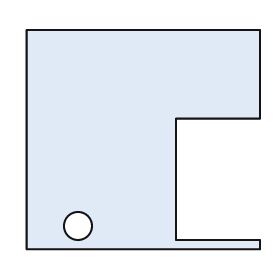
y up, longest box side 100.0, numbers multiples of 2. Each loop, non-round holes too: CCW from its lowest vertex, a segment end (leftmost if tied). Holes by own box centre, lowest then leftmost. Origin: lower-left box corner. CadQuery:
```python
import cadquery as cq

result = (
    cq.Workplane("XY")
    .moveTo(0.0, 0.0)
    .lineTo(100.0, 0.0)
    .lineTo(100.0, 4.0)
    .lineTo(64.0, 4.0)
    .lineTo(64.0, 56.0)
    .lineTo(100.0, 56.0)
    .lineTo(100.0, 94.0)
    .lineTo(0.0, 94.0)
    .close()
    .moveTo(22.0, 10.0)
    .circle(6.0)
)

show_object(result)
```